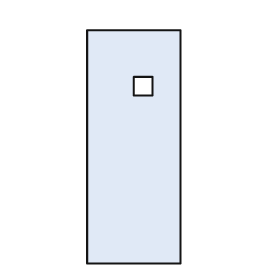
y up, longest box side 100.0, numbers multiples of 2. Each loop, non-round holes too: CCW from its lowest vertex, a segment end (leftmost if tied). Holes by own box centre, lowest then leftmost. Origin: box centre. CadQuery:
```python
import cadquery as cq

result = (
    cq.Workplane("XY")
    .moveTo(-20.0, -50.0)
    .lineTo(20.0, -50.0)
    .lineTo(20.0, 50.0)
    .lineTo(-20.0, 50.0)
    .close()
    .moveTo(0.0, 22.0)
    .lineTo(8.0, 22.0)
    .lineTo(8.0, 30.0)
    .lineTo(0.0, 30.0)
    .close()
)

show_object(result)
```